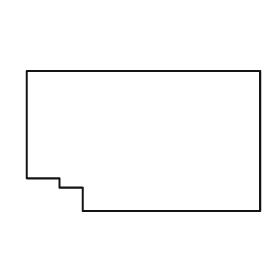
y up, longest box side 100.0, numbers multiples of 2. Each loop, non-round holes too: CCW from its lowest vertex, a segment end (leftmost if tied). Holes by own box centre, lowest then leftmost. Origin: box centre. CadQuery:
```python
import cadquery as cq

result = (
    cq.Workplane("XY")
    .moveTo(-26.0, -30.0)
    .lineTo(50.0, -30.0)
    .lineTo(50.0, 30.0)
    .lineTo(-50.0, 30.0)
    .lineTo(-50.0, -16.0)
    .lineTo(-36.0, -16.0)
    .lineTo(-36.0, -20.0)
    .lineTo(-26.0, -20.0)
    .close()
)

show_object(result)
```